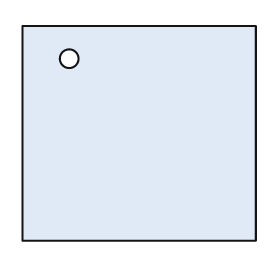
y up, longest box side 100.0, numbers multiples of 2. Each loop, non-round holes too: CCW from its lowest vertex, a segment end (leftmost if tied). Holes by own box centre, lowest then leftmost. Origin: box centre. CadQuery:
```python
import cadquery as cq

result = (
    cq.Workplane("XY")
    .moveTo(-50.0, -46.0)
    .lineTo(50.0, -46.0)
    .lineTo(50.0, 46.0)
    .lineTo(-50.0, 46.0)
    .close()
    .moveTo(-30.0, 32.0)
    .circle(4.0)
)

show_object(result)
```